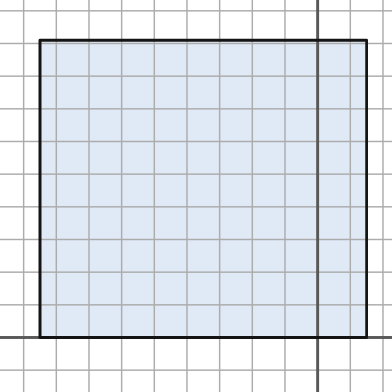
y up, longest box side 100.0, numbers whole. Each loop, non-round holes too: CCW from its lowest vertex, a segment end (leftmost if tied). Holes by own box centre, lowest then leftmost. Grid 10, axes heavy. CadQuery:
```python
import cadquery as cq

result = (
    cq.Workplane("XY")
    .moveTo(-85.0, 0.0)
    .lineTo(15.0, 0.0)
    .lineTo(15.0, 91.0)
    .lineTo(-85.0, 91.0)
    .close()
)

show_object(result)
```